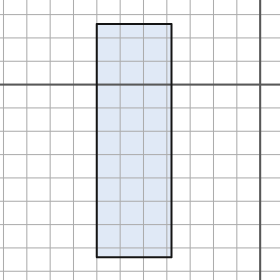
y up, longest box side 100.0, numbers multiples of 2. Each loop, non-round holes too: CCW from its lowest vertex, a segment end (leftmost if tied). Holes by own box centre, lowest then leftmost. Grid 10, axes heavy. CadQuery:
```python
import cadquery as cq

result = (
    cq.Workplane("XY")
    .moveTo(-70.0, -74.0)
    .lineTo(-38.0, -74.0)
    .lineTo(-38.0, 26.0)
    .lineTo(-70.0, 26.0)
    .close()
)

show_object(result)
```